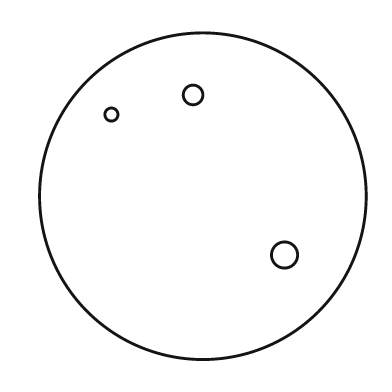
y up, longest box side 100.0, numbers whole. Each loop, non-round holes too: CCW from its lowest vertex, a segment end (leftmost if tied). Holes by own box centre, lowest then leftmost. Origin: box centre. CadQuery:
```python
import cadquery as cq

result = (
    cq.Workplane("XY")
    .moveTo(0.0, 0.0)
    .circle(50.0)
    .moveTo(25.0, -18.0)
    .circle(4.0)
    .moveTo(-28.0, 25.0)
    .circle(2.0)
    .moveTo(-3.0, 31.0)
    .circle(3.0)
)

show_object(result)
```